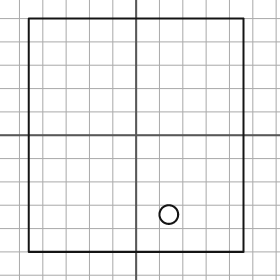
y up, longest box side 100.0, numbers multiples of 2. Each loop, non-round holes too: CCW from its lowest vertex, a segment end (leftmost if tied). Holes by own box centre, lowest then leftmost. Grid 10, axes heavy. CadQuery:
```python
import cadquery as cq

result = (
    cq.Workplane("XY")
    .moveTo(-46.0, -50.0)
    .lineTo(46.0, -50.0)
    .lineTo(46.0, 50.0)
    .lineTo(-46.0, 50.0)
    .close()
    .moveTo(14.0, -34.0)
    .circle(4.0)
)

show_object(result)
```